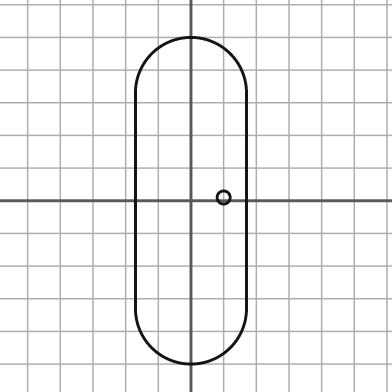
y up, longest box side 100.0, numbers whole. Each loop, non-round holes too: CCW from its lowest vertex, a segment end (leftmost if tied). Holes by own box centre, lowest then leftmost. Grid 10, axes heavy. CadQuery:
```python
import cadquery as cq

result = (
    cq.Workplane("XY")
    .moveTo(-17.0, -33.0)
    .threePointArc((0.0, -50.0), (17.0, -33.0))
    .lineTo(17.0, 33.0)
    .threePointArc((0.0, 50.0), (-17.0, 33.0))
    .close()
    .moveTo(10.0, 1.0)
    .circle(2.0)
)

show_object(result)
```